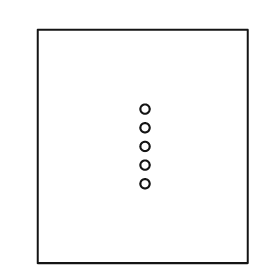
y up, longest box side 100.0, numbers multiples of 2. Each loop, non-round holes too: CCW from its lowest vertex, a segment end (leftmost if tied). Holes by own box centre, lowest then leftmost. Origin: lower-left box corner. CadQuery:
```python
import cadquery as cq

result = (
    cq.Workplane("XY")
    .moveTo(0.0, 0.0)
    .lineTo(90.0, 0.0)
    .lineTo(90.0, 100.0)
    .lineTo(0.0, 100.0)
    .close()
    .moveTo(46.0, 34.0)
    .circle(2.0)
    .moveTo(46.0, 42.0)
    .circle(2.0)
    .moveTo(46.0, 50.0)
    .circle(2.0)
    .moveTo(46.0, 58.0)
    .circle(2.0)
    .moveTo(46.0, 66.0)
    .circle(2.0)
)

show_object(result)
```